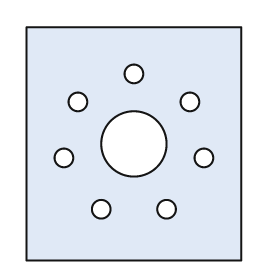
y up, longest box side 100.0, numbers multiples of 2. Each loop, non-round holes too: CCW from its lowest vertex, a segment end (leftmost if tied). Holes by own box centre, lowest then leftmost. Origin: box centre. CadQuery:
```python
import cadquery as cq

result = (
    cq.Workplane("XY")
    .moveTo(-46.0, -50.0)
    .lineTo(46.0, -50.0)
    .lineTo(46.0, 50.0)
    .lineTo(-46.0, 50.0)
    .close()
    .moveTo(-14.0, -28.0)
    .circle(4.0)
    .moveTo(14.0, -28.0)
    .circle(4.0)
    .moveTo(-30.0, -6.0)
    .circle(4.0)
    .moveTo(30.0, -6.0)
    .circle(4.0)
    .moveTo(0.0, 0.0)
    .circle(14.0)
    .moveTo(-24.0, 18.0)
    .circle(4.0)
    .moveTo(24.0, 18.0)
    .circle(4.0)
    .moveTo(0.0, 30.0)
    .circle(4.0)
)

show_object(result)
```